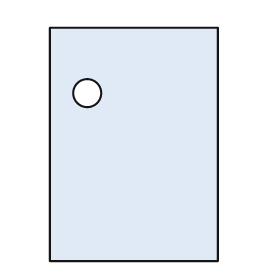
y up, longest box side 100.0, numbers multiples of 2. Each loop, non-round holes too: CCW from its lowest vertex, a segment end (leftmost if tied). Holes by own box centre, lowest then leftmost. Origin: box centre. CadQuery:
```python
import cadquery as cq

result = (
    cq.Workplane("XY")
    .moveTo(-36.0, -50.0)
    .lineTo(36.0, -50.0)
    .lineTo(36.0, 50.0)
    .lineTo(-36.0, 50.0)
    .close()
    .moveTo(-20.0, 22.0)
    .circle(6.0)
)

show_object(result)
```